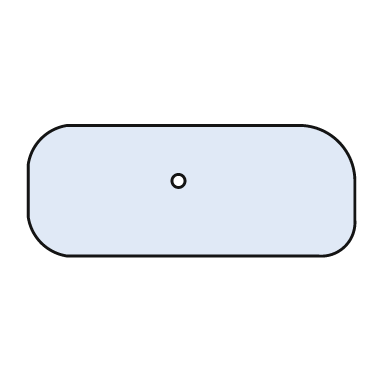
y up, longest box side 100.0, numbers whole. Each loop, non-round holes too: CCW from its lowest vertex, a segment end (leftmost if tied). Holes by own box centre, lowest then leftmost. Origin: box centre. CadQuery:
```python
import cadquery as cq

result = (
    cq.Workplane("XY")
    .moveTo(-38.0, -20.0)
    .lineTo(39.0, -20.0)
    .threePointArc((47.0, -17.0), (50.0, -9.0))
    .lineTo(50.0, 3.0)
    .threePointArc((45.0, 15.0), (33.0, 20.0))
    .lineTo(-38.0, 20.0)
    .threePointArc((-46.0, 16.0), (-50.0, 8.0))
    .lineTo(-50.0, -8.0)
    .threePointArc((-46.0, -16.0), (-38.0, -20.0))
    .close()
    .moveTo(-4.0, 3.0)
    .circle(2.0)
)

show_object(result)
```